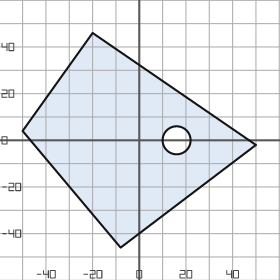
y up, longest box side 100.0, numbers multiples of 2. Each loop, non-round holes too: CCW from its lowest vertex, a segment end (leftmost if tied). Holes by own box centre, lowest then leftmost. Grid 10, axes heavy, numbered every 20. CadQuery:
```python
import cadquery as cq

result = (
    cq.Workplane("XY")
    .moveTo(-8.0, -46.0)
    .lineTo(50.0, -2.0)
    .lineTo(-20.0, 46.0)
    .lineTo(-50.0, 4.0)
    .close()
    .moveTo(16.0, 0.0)
    .circle(6.0)
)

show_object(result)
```